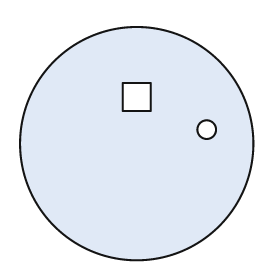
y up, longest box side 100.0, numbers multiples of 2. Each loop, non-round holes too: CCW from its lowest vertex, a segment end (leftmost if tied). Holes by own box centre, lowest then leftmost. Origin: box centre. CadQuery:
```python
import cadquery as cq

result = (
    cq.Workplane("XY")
    .moveTo(0.0, 0.0)
    .circle(50.0)
    .moveTo(30.0, 6.0)
    .circle(4.0)
    .moveTo(-6.0, 14.0)
    .lineTo(6.0, 14.0)
    .lineTo(6.0, 26.0)
    .lineTo(-6.0, 26.0)
    .close()
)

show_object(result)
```